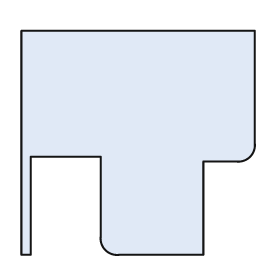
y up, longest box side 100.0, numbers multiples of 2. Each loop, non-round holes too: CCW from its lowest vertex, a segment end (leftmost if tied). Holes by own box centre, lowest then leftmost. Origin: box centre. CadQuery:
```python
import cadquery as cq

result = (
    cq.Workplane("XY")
    .moveTo(-50.0, -48.0)
    .lineTo(-46.0, -48.0)
    .lineTo(-46.0, -6.0)
    .lineTo(-16.0, -6.0)
    .lineTo(-16.0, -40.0)
    .threePointArc((-14.0, -46.0), (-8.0, -48.0))
    .lineTo(28.0, -48.0)
    .lineTo(28.0, -8.0)
    .lineTo(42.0, -8.0)
    .threePointArc((48.0, -6.0), (50.0, 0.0))
    .lineTo(50.0, 48.0)
    .lineTo(-50.0, 48.0)
    .close()
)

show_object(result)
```